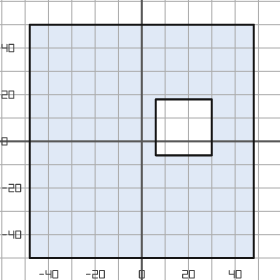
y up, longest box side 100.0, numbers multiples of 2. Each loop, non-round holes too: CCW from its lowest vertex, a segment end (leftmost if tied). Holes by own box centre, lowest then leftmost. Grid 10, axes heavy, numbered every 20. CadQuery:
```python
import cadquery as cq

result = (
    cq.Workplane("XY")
    .moveTo(-48.0, -50.0)
    .lineTo(48.0, -50.0)
    .lineTo(48.0, 50.0)
    .lineTo(-48.0, 50.0)
    .close()
    .moveTo(6.0, -6.0)
    .lineTo(30.0, -6.0)
    .lineTo(30.0, 18.0)
    .lineTo(6.0, 18.0)
    .close()
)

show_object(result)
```